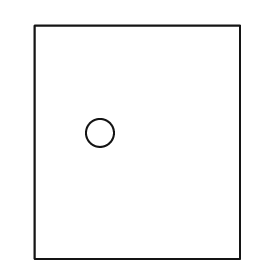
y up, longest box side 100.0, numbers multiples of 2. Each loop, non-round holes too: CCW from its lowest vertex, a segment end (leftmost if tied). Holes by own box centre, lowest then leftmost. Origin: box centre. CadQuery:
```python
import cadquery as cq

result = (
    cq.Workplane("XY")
    .moveTo(-44.0, -50.0)
    .lineTo(44.0, -50.0)
    .lineTo(44.0, 50.0)
    .lineTo(-44.0, 50.0)
    .close()
    .moveTo(-16.0, 4.0)
    .circle(6.0)
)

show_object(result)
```